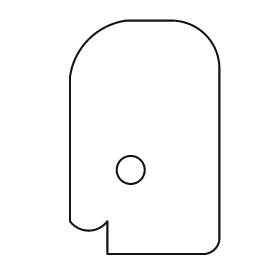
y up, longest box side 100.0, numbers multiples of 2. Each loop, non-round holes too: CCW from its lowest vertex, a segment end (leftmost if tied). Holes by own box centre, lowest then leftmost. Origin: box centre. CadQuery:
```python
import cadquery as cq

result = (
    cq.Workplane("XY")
    .moveTo(-16.0, -50.0)
    .lineTo(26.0, -50.0)
    .threePointArc((30.0, -48.0), (32.0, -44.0))
    .lineTo(32.0, 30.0)
    .threePointArc((26.0, 44.0), (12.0, 50.0))
    .lineTo(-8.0, 50.0)
    .threePointArc((-24.0, 42.0), (-32.0, 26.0))
    .lineTo(-32.0, -36.0)
    .threePointArc((-24.0, -40.0), (-16.0, -36.0))
    .close()
    .moveTo(-6.0, -14.0)
    .circle(6.0)
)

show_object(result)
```